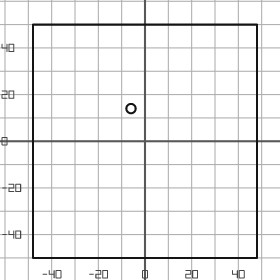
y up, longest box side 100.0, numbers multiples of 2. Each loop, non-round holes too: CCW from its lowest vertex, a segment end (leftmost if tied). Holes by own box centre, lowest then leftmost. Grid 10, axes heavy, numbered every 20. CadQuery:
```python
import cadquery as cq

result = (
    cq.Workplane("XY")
    .moveTo(-48.0, -50.0)
    .lineTo(48.0, -50.0)
    .lineTo(48.0, 50.0)
    .lineTo(-48.0, 50.0)
    .close()
    .moveTo(-6.0, 14.0)
    .circle(2.0)
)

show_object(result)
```